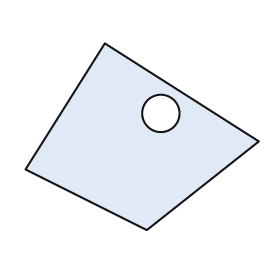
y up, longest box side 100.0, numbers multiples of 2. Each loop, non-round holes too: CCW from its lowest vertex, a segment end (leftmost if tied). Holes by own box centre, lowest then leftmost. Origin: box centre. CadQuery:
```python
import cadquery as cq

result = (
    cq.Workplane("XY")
    .moveTo(2.0, -40.0)
    .lineTo(50.0, -2.0)
    .lineTo(-16.0, 40.0)
    .lineTo(-50.0, -14.0)
    .close()
    .moveTo(8.0, 10.0)
    .circle(8.0)
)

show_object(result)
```